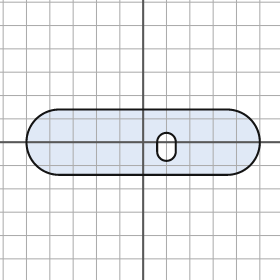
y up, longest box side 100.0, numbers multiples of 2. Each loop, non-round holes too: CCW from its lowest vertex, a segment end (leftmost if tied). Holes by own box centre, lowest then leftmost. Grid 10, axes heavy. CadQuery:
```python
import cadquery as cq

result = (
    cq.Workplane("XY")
    .moveTo(-36.0, -14.0)
    .lineTo(36.0, -14.0)
    .threePointArc((50.0, 0.0), (36.0, 14.0))
    .lineTo(-36.0, 14.0)
    .threePointArc((-50.0, 0.0), (-36.0, -14.0))
    .close()
    .moveTo(6.0, -4.0)
    .threePointArc((10.0, -8.0), (14.0, -4.0))
    .lineTo(14.0, 0.0)
    .threePointArc((10.0, 4.0), (6.0, 0.0))
    .close()
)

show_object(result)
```